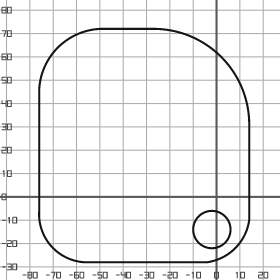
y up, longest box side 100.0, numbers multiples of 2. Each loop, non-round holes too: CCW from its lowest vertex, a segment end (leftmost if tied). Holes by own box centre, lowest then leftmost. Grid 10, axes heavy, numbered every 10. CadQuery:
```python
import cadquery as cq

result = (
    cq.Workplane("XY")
    .moveTo(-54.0, -28.0)
    .lineTo(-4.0, -28.0)
    .threePointArc((8.0, -22.0), (14.0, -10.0))
    .lineTo(14.0, 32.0)
    .threePointArc((2.0, 60.0), (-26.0, 72.0))
    .lineTo(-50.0, 72.0)
    .threePointArc((-68.0, 64.0), (-76.0, 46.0))
    .lineTo(-76.0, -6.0)
    .threePointArc((-70.0, -22.0), (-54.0, -28.0))
    .close()
    .moveTo(-2.0, -14.0)
    .circle(8.0)
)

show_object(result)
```